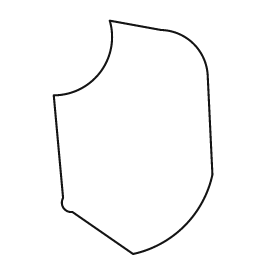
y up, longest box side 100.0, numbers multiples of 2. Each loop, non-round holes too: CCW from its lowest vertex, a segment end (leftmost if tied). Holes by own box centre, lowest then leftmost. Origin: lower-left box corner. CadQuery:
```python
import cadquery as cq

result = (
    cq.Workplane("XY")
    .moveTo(34.0, 0.0)
    .threePointArc((56.0, 12.0), (68.0, 34.0))
    .lineTo(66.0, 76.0)
    .threePointArc((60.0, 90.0), (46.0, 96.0))
    .lineTo(24.0, 100.0)
    .threePointArc((20.0, 78.0), (0.0, 68.0))
    .lineTo(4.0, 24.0)
    .threePointArc((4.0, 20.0), (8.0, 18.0))
    .close()
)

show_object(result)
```